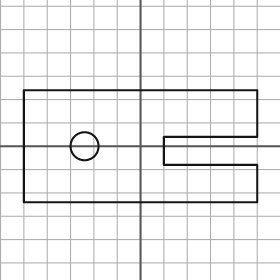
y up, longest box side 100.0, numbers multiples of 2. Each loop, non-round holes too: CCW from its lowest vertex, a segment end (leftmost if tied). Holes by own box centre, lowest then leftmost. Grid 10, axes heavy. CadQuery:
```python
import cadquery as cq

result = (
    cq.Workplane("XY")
    .moveTo(-50.0, -24.0)
    .lineTo(50.0, -24.0)
    .lineTo(50.0, -8.0)
    .lineTo(10.0, -8.0)
    .lineTo(10.0, 4.0)
    .lineTo(50.0, 4.0)
    .lineTo(50.0, 24.0)
    .lineTo(-50.0, 24.0)
    .close()
    .moveTo(-24.0, 0.0)
    .circle(6.0)
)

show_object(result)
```